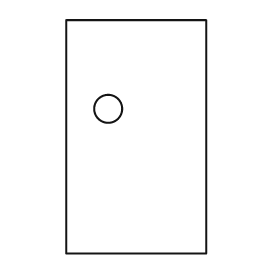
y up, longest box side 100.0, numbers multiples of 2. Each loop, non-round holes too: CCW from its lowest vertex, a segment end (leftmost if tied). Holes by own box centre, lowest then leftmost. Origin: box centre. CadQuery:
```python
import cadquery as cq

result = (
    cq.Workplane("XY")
    .moveTo(-30.0, -50.0)
    .lineTo(30.0, -50.0)
    .lineTo(30.0, 50.0)
    .lineTo(-30.0, 50.0)
    .close()
    .moveTo(-12.0, 12.0)
    .circle(6.0)
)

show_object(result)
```